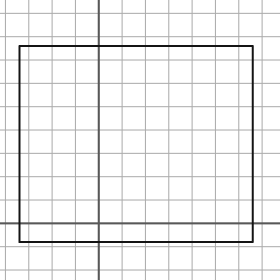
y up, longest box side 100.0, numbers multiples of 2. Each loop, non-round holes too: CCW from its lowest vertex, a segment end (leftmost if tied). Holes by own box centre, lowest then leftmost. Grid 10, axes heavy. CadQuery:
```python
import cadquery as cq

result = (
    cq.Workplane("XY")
    .moveTo(-34.0, -8.0)
    .lineTo(66.0, -8.0)
    .lineTo(66.0, 76.0)
    .lineTo(-34.0, 76.0)
    .close()
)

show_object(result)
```